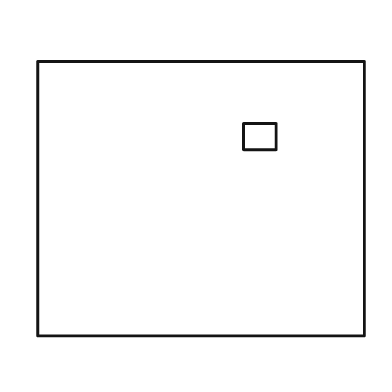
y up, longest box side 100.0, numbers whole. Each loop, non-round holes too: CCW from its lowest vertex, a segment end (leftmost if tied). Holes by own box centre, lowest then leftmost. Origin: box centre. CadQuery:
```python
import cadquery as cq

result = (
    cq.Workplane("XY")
    .moveTo(-50.0, -42.0)
    .lineTo(50.0, -42.0)
    .lineTo(50.0, 42.0)
    .lineTo(-50.0, 42.0)
    .close()
    .moveTo(13.0, 15.0)
    .lineTo(23.0, 15.0)
    .lineTo(23.0, 23.0)
    .lineTo(13.0, 23.0)
    .close()
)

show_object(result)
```